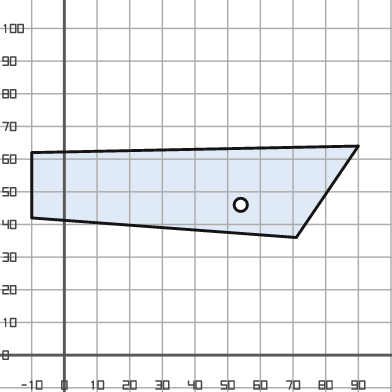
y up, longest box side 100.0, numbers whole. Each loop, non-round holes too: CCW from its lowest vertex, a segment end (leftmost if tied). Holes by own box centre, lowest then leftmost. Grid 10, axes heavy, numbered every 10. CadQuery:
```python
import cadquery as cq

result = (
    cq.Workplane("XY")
    .moveTo(71.0, 36.0)
    .lineTo(90.0, 64.0)
    .lineTo(-10.0, 62.0)
    .lineTo(-10.0, 42.0)
    .close()
    .moveTo(54.0, 46.0)
    .circle(2.0)
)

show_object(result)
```